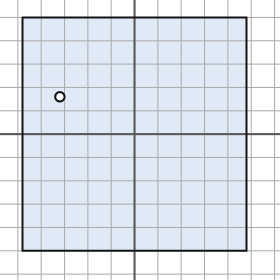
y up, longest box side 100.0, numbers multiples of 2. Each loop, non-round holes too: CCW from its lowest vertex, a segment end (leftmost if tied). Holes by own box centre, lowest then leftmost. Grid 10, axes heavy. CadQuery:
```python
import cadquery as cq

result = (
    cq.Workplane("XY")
    .moveTo(-48.0, -50.0)
    .lineTo(48.0, -50.0)
    .lineTo(48.0, 50.0)
    .lineTo(-48.0, 50.0)
    .close()
    .moveTo(-32.0, 16.0)
    .circle(2.0)
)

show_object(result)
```